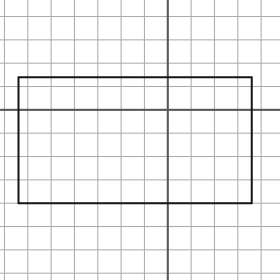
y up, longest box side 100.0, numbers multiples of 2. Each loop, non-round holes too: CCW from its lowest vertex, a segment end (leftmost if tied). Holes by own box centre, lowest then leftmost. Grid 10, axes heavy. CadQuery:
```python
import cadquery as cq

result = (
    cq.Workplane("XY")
    .moveTo(-64.0, -40.0)
    .lineTo(36.0, -40.0)
    .lineTo(36.0, 14.0)
    .lineTo(-64.0, 14.0)
    .close()
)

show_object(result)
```